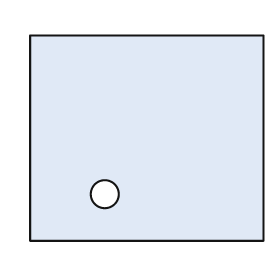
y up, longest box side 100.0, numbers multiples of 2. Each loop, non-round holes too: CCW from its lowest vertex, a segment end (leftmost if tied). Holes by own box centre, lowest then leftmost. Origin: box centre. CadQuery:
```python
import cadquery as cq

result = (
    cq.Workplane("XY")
    .moveTo(-50.0, -44.0)
    .lineTo(50.0, -44.0)
    .lineTo(50.0, 44.0)
    .lineTo(-50.0, 44.0)
    .close()
    .moveTo(-18.0, -24.0)
    .circle(6.0)
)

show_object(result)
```